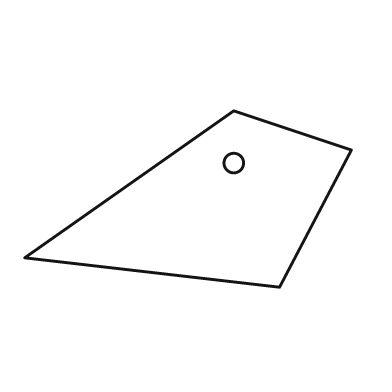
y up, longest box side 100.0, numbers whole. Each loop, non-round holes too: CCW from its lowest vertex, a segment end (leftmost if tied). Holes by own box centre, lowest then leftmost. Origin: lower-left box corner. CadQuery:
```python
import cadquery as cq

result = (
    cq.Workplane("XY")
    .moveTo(78.0, 0.0)
    .lineTo(100.0, 42.0)
    .lineTo(64.0, 54.0)
    .lineTo(0.0, 9.0)
    .close()
    .moveTo(64.0, 38.0)
    .circle(3.0)
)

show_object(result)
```